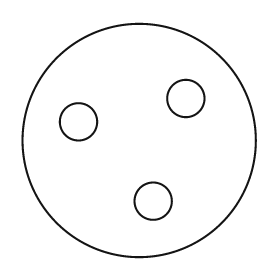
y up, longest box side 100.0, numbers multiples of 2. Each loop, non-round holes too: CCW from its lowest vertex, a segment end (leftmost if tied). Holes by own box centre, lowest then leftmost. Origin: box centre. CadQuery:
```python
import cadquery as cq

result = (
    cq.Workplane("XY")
    .moveTo(0.0, 0.0)
    .circle(50.0)
    .moveTo(6.0, -26.0)
    .circle(8.0)
    .moveTo(-26.0, 8.0)
    .circle(8.0)
    .moveTo(20.0, 18.0)
    .circle(8.0)
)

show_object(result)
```